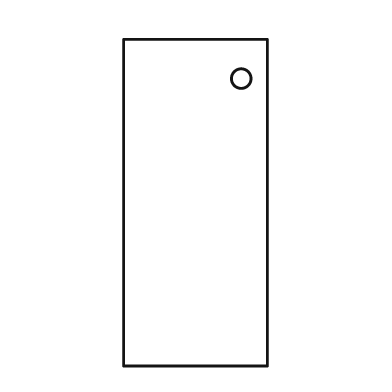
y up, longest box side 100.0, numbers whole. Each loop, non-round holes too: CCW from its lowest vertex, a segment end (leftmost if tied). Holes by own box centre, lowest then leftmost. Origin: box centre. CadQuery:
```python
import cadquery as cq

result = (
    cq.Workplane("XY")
    .moveTo(-22.0, -50.0)
    .lineTo(22.0, -50.0)
    .lineTo(22.0, 50.0)
    .lineTo(-22.0, 50.0)
    .close()
    .moveTo(14.0, 38.0)
    .circle(3.0)
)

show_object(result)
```